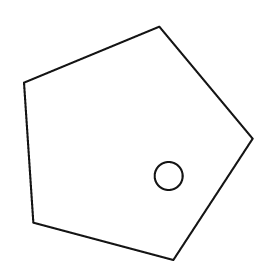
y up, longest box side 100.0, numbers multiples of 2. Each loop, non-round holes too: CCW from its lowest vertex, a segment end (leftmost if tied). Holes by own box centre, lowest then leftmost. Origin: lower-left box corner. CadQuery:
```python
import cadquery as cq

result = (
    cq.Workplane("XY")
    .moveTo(64.0, 0.0)
    .lineTo(98.0, 52.0)
    .lineTo(58.0, 100.0)
    .lineTo(0.0, 76.0)
    .lineTo(4.0, 16.0)
    .close()
    .moveTo(62.0, 36.0)
    .circle(6.0)
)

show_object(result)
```